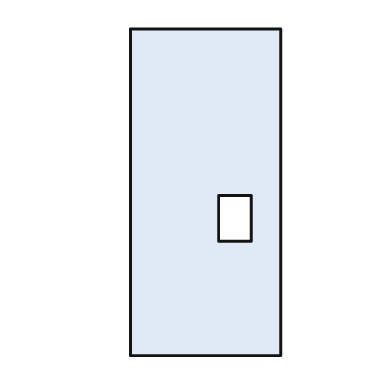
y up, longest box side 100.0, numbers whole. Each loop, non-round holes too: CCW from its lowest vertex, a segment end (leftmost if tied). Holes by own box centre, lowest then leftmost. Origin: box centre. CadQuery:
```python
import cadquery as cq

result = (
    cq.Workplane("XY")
    .moveTo(-23.0, -50.0)
    .lineTo(23.0, -50.0)
    .lineTo(23.0, 50.0)
    .lineTo(-23.0, 50.0)
    .close()
    .moveTo(4.0, -15.0)
    .lineTo(14.0, -15.0)
    .lineTo(14.0, -1.0)
    .lineTo(4.0, -1.0)
    .close()
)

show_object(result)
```